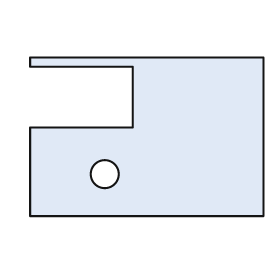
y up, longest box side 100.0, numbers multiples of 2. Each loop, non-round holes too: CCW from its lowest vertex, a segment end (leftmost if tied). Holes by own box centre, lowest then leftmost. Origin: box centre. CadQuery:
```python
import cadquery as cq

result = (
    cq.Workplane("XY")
    .moveTo(-50.0, -34.0)
    .lineTo(50.0, -34.0)
    .lineTo(50.0, 34.0)
    .lineTo(-50.0, 34.0)
    .lineTo(-50.0, 30.0)
    .lineTo(-6.0, 30.0)
    .lineTo(-6.0, 4.0)
    .lineTo(-50.0, 4.0)
    .close()
    .moveTo(-18.0, -16.0)
    .circle(6.0)
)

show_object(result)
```